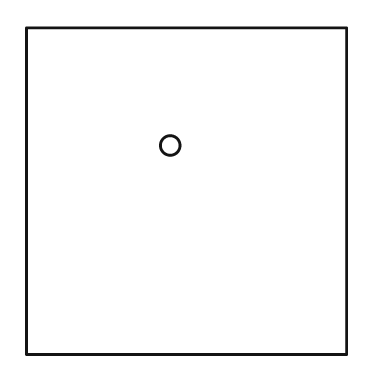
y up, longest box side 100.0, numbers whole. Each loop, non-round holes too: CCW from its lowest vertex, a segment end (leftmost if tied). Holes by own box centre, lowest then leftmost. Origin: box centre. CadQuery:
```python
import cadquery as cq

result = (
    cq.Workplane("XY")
    .moveTo(-49.0, -50.0)
    .lineTo(49.0, -50.0)
    .lineTo(49.0, 50.0)
    .lineTo(-49.0, 50.0)
    .close()
    .moveTo(-5.0, 14.0)
    .circle(3.0)
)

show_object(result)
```